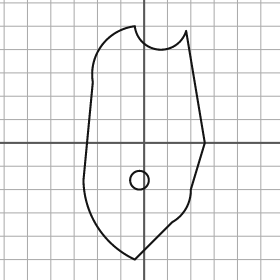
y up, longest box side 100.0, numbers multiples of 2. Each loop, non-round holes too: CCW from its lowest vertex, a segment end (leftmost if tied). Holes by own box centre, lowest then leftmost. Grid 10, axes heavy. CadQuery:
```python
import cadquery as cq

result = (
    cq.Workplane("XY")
    .moveTo(-4.0, -50.0)
    .lineTo(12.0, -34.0)
    .threePointArc((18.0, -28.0), (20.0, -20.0))
    .lineTo(26.0, 0.0)
    .lineTo(18.0, 48.0)
    .threePointArc((6.0, 40.0), (-4.0, 50.0))
    .threePointArc((-18.0, 42.0), (-22.0, 26.0))
    .lineTo(-26.0, -16.0)
    .threePointArc((-20.0, -36.0), (-4.0, -50.0))
    .close()
    .moveTo(-2.0, -16.0)
    .circle(4.0)
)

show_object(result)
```